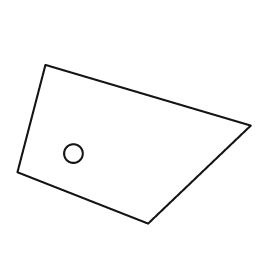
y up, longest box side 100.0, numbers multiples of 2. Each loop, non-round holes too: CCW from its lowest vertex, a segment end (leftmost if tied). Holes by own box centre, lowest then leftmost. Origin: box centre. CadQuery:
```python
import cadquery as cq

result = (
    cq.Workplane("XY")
    .moveTo(6.0, -34.0)
    .lineTo(50.0, 8.0)
    .lineTo(-38.0, 34.0)
    .lineTo(-50.0, -12.0)
    .close()
    .moveTo(-26.0, -4.0)
    .circle(4.0)
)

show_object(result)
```